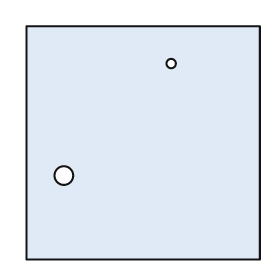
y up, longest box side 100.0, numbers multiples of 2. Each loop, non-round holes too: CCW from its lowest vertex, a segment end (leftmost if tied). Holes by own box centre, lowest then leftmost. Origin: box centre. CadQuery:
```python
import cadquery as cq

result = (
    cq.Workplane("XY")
    .moveTo(-50.0, -50.0)
    .lineTo(50.0, -50.0)
    .lineTo(50.0, 50.0)
    .lineTo(-50.0, 50.0)
    .close()
    .moveTo(-34.0, -14.0)
    .circle(4.0)
    .moveTo(12.0, 34.0)
    .circle(2.0)
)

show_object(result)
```